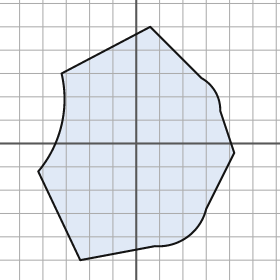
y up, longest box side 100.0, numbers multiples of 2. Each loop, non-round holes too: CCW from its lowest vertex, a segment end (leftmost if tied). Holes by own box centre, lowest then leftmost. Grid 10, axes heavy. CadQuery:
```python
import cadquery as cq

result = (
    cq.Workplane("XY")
    .moveTo(-24.0, -50.0)
    .lineTo(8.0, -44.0)
    .threePointArc((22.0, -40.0), (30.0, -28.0))
    .lineTo(42.0, -4.0)
    .lineTo(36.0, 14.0)
    .threePointArc((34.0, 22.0), (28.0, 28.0))
    .lineTo(6.0, 50.0)
    .lineTo(-32.0, 30.0)
    .threePointArc((-32.0, 8.0), (-42.0, -12.0))
    .close()
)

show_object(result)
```